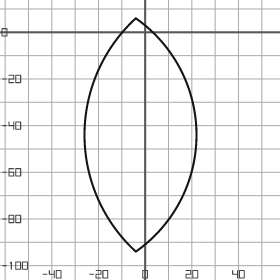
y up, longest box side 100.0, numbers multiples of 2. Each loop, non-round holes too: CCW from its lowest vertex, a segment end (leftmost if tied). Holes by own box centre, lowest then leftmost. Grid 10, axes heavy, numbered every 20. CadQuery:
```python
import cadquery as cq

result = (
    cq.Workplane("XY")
    .moveTo(-4.0, -94.0)
    .threePointArc((22.0, -44.0), (-4.0, 6.0))
    .threePointArc((-26.0, -44.0), (-4.0, -94.0))
    .close()
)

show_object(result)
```